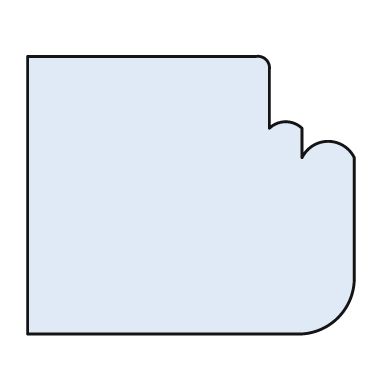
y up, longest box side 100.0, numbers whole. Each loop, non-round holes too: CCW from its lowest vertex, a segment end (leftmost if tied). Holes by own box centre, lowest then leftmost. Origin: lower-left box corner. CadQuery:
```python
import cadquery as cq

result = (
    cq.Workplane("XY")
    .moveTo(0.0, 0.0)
    .lineTo(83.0, 0.0)
    .threePointArc((95.0, 5.0), (100.0, 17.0))
    .lineTo(100.0, 54.0)
    .threePointArc((92.0, 59.0), (84.0, 54.0))
    .lineTo(84.0, 63.0)
    .threePointArc((79.0, 65.0), (74.0, 63.0))
    .lineTo(74.0, 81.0)
    .threePointArc((73.0, 84.0), (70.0, 85.0))
    .lineTo(0.0, 85.0)
    .close()
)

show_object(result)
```